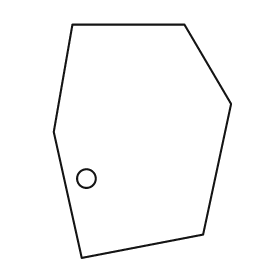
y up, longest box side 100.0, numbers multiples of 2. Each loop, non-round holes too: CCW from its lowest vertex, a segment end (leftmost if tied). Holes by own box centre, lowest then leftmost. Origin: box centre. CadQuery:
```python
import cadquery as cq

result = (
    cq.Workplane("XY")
    .moveTo(-26.0, -50.0)
    .lineTo(26.0, -40.0)
    .lineTo(38.0, 16.0)
    .lineTo(18.0, 50.0)
    .lineTo(-30.0, 50.0)
    .lineTo(-38.0, 4.0)
    .close()
    .moveTo(-24.0, -16.0)
    .circle(4.0)
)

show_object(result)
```